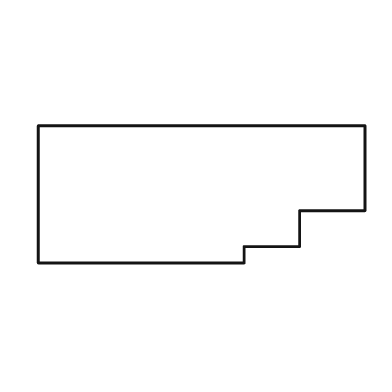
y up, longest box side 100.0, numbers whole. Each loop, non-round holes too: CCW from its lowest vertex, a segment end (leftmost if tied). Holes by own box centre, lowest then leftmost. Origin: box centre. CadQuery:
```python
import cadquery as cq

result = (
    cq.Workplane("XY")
    .moveTo(-50.0, -21.0)
    .lineTo(13.0, -21.0)
    .lineTo(13.0, -16.0)
    .lineTo(30.0, -16.0)
    .lineTo(30.0, -5.0)
    .lineTo(50.0, -5.0)
    .lineTo(50.0, 21.0)
    .lineTo(-50.0, 21.0)
    .close()
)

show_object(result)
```